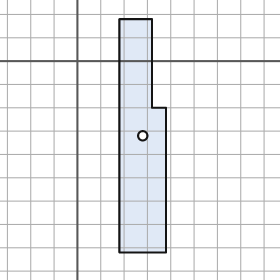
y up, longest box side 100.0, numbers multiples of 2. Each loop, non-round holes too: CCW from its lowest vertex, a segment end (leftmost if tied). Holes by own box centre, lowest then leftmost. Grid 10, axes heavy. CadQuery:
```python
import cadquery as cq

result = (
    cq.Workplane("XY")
    .moveTo(18.0, -82.0)
    .lineTo(38.0, -82.0)
    .lineTo(38.0, -20.0)
    .lineTo(32.0, -20.0)
    .lineTo(32.0, 18.0)
    .lineTo(18.0, 18.0)
    .close()
    .moveTo(28.0, -32.0)
    .circle(2.0)
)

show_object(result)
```